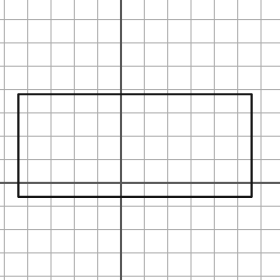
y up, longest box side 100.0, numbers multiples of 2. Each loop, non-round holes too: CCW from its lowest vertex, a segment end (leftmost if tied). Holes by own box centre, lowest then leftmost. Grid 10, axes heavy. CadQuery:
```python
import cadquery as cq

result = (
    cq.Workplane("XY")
    .moveTo(-44.0, -6.0)
    .lineTo(56.0, -6.0)
    .lineTo(56.0, 38.0)
    .lineTo(-44.0, 38.0)
    .close()
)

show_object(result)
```